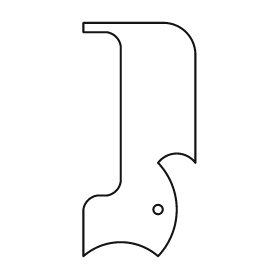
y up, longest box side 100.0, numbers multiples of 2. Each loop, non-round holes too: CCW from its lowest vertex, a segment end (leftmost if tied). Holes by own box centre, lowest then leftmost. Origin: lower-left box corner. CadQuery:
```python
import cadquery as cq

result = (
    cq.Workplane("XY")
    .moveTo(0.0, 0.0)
    .threePointArc((16.0, 6.0), (32.0, 0.0))
    .threePointArc((40.0, 20.0), (32.0, 40.0))
    .threePointArc((40.0, 44.0), (48.0, 40.0))
    .lineTo(48.0, 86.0)
    .threePointArc((44.0, 96.0), (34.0, 100.0))
    .lineTo(0.0, 100.0)
    .lineTo(0.0, 96.0)
    .lineTo(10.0, 96.0)
    .threePointArc((14.0, 94.0), (16.0, 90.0))
    .lineTo(16.0, 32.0)
    .threePointArc((14.0, 28.0), (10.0, 26.0))
    .lineTo(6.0, 26.0)
    .threePointArc((2.0, 24.0), (0.0, 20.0))
    .close()
    .moveTo(32.0, 20.0)
    .circle(2.0)
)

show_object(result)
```